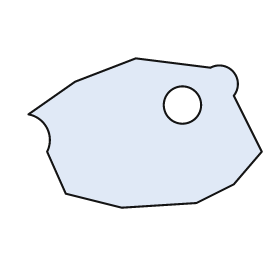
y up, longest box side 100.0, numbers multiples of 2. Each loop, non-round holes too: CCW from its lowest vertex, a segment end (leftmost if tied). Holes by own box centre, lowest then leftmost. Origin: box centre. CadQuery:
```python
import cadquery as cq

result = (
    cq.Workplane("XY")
    .moveTo(-10.0, -32.0)
    .lineTo(22.0, -30.0)
    .lineTo(38.0, -22.0)
    .lineTo(50.0, -8.0)
    .lineTo(38.0, 16.0)
    .threePointArc((38.0, 26.0), (28.0, 28.0))
    .lineTo(-4.0, 32.0)
    .lineTo(-30.0, 22.0)
    .lineTo(-50.0, 8.0)
    .threePointArc((-42.0, 2.0), (-42.0, -8.0))
    .lineTo(-34.0, -26.0)
    .close()
    .moveTo(16.0, 12.0)
    .circle(8.0)
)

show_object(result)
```